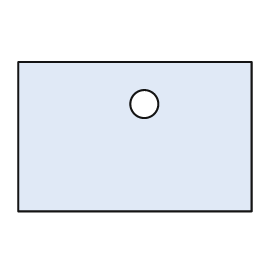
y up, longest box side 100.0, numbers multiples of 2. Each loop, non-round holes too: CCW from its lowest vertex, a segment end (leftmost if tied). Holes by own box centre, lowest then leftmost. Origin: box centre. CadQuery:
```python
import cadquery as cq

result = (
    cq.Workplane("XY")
    .moveTo(-50.0, -32.0)
    .lineTo(50.0, -32.0)
    .lineTo(50.0, 32.0)
    .lineTo(-50.0, 32.0)
    .close()
    .moveTo(4.0, 14.0)
    .circle(6.0)
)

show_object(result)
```